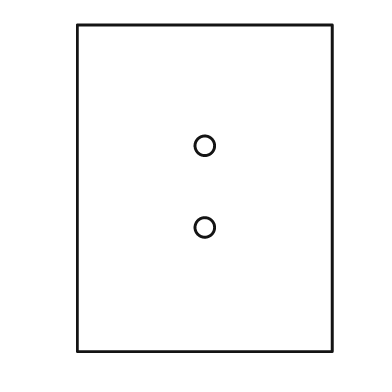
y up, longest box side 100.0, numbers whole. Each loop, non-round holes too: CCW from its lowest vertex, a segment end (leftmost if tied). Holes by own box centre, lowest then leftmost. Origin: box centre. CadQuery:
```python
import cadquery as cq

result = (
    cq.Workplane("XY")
    .moveTo(-39.0, -50.0)
    .lineTo(39.0, -50.0)
    .lineTo(39.0, 50.0)
    .lineTo(-39.0, 50.0)
    .close()
    .moveTo(0.0, -12.0)
    .circle(3.0)
    .moveTo(0.0, 13.0)
    .circle(3.0)
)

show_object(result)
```